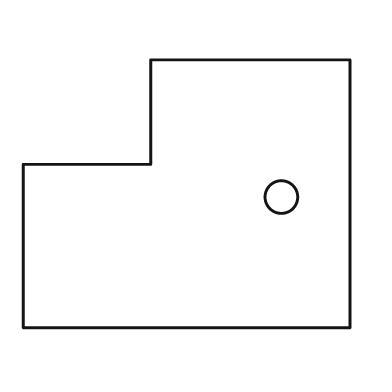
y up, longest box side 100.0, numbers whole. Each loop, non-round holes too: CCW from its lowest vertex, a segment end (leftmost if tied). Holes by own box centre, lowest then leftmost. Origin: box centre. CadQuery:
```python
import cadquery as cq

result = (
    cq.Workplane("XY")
    .moveTo(-50.0, -41.0)
    .lineTo(50.0, -41.0)
    .lineTo(50.0, 41.0)
    .lineTo(-11.0, 41.0)
    .lineTo(-11.0, 9.0)
    .lineTo(-50.0, 9.0)
    .close()
    .moveTo(29.0, -1.0)
    .circle(5.0)
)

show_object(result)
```